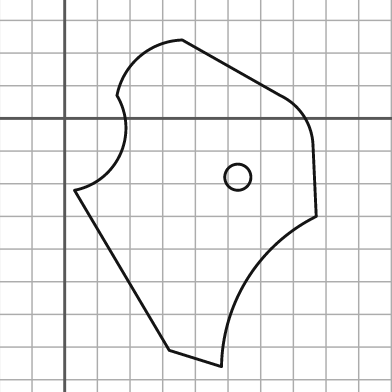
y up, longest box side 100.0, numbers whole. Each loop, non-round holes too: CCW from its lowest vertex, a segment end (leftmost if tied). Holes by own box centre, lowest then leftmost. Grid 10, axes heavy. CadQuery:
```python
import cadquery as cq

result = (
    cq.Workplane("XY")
    .moveTo(48.0, -76.0)
    .threePointArc((56.0, -49.0), (77.0, -30.0))
    .lineTo(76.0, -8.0)
    .threePointArc((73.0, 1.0), (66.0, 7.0))
    .lineTo(36.0, 24.0)
    .threePointArc((23.0, 19.0), (16.0, 7.0))
    .threePointArc((17.0, -11.0), (3.0, -22.0))
    .lineTo(32.0, -71.0)
    .close()
    .moveTo(53.0, -18.0)
    .circle(4.0)
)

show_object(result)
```